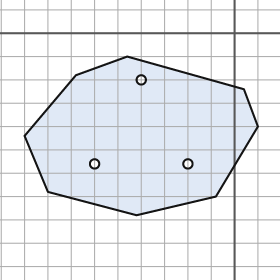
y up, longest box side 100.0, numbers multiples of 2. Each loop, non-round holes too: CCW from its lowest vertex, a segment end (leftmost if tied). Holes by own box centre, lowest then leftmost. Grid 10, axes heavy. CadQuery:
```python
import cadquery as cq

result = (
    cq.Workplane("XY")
    .moveTo(-42.0, -78.0)
    .lineTo(-8.0, -70.0)
    .lineTo(10.0, -40.0)
    .lineTo(4.0, -24.0)
    .lineTo(-46.0, -10.0)
    .lineTo(-68.0, -18.0)
    .lineTo(-90.0, -44.0)
    .lineTo(-80.0, -68.0)
    .close()
    .moveTo(-60.0, -56.0)
    .circle(2.0)
    .moveTo(-20.0, -56.0)
    .circle(2.0)
    .moveTo(-40.0, -20.0)
    .circle(2.0)
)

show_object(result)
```